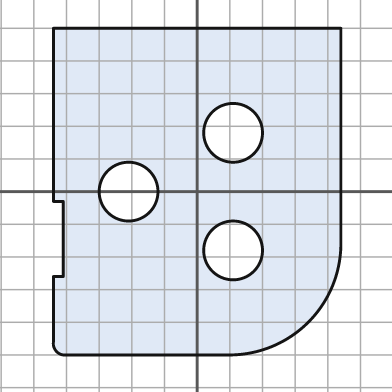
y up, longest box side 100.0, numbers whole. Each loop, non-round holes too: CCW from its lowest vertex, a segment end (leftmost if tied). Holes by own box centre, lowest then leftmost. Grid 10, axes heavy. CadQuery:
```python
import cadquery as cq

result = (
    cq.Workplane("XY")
    .moveTo(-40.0, -50.0)
    .lineTo(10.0, -50.0)
    .threePointArc((34.0, -40.0), (44.0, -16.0))
    .lineTo(44.0, 50.0)
    .lineTo(-44.0, 50.0)
    .lineTo(-44.0, -3.0)
    .lineTo(-41.0, -3.0)
    .lineTo(-41.0, -26.0)
    .lineTo(-44.0, -26.0)
    .lineTo(-44.0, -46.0)
    .threePointArc((-43.0, -49.0), (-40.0, -50.0))
    .close()
    .moveTo(11.0, -18.0)
    .circle(9.0)
    .moveTo(-21.0, 0.0)
    .circle(9.0)
    .moveTo(11.0, 18.0)
    .circle(9.0)
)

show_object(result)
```